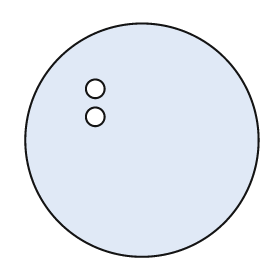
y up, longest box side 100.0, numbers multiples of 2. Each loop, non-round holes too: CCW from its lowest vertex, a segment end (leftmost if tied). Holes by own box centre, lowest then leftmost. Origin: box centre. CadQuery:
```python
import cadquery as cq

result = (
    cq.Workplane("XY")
    .moveTo(0.0, 0.0)
    .circle(50.0)
    .moveTo(-20.0, 10.0)
    .circle(4.0)
    .moveTo(-20.0, 22.0)
    .circle(4.0)
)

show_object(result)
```